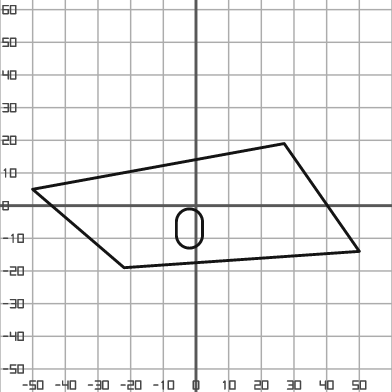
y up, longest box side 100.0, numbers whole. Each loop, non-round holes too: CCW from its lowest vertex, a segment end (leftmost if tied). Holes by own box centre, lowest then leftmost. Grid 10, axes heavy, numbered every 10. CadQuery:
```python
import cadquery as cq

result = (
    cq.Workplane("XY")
    .moveTo(-22.0, -19.0)
    .lineTo(50.0, -14.0)
    .lineTo(27.0, 19.0)
    .lineTo(-50.0, 5.0)
    .close()
    .moveTo(-6.0, -9.0)
    .threePointArc((-2.0, -13.0), (2.0, -9.0))
    .lineTo(2.0, -5.0)
    .threePointArc((-2.0, -1.0), (-6.0, -5.0))
    .close()
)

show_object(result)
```